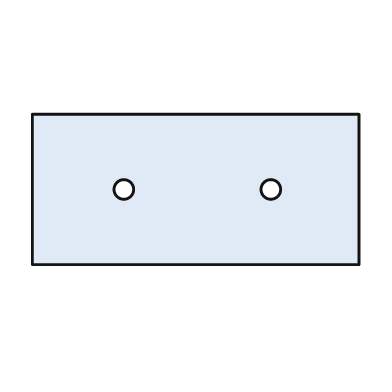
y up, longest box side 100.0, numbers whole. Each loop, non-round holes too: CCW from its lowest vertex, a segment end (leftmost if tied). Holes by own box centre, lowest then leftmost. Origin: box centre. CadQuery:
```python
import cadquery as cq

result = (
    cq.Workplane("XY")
    .moveTo(-50.0, -23.0)
    .lineTo(50.0, -23.0)
    .lineTo(50.0, 23.0)
    .lineTo(-50.0, 23.0)
    .close()
    .moveTo(-22.0, 0.0)
    .circle(3.0)
    .moveTo(23.0, 0.0)
    .circle(3.0)
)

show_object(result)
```